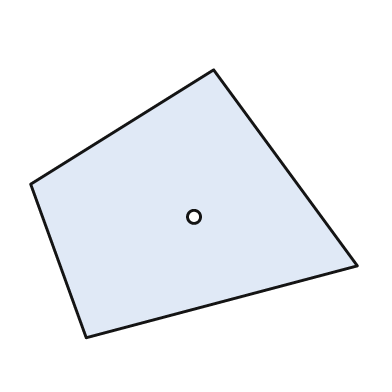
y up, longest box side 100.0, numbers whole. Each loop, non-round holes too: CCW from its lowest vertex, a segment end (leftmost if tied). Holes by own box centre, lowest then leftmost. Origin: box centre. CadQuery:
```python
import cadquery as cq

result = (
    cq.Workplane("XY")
    .moveTo(-33.0, -41.0)
    .lineTo(50.0, -19.0)
    .lineTo(6.0, 41.0)
    .lineTo(-50.0, 6.0)
    .close()
    .moveTo(0.0, -4.0)
    .circle(2.0)
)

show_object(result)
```